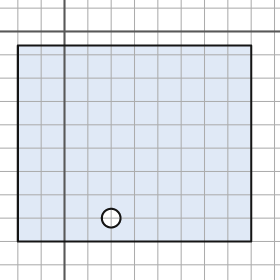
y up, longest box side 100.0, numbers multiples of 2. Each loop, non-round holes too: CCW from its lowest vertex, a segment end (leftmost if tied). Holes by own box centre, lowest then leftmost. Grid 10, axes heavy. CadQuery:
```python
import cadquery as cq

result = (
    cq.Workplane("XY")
    .moveTo(-20.0, -90.0)
    .lineTo(80.0, -90.0)
    .lineTo(80.0, -6.0)
    .lineTo(-20.0, -6.0)
    .close()
    .moveTo(20.0, -80.0)
    .circle(4.0)
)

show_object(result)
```